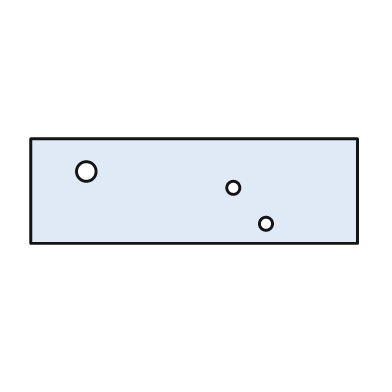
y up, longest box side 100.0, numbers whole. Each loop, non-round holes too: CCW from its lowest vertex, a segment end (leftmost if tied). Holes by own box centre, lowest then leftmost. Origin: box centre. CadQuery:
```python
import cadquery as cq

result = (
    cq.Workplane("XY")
    .moveTo(-50.0, -16.0)
    .lineTo(50.0, -16.0)
    .lineTo(50.0, 16.0)
    .lineTo(-50.0, 16.0)
    .close()
    .moveTo(22.0, -10.0)
    .circle(2.0)
    .moveTo(12.0, 1.0)
    .circle(2.0)
    .moveTo(-33.0, 6.0)
    .circle(3.0)
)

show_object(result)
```